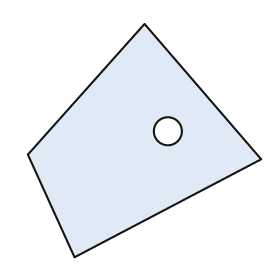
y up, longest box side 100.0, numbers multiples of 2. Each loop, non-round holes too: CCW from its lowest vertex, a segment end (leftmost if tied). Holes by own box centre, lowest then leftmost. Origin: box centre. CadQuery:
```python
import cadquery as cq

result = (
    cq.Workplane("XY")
    .moveTo(-30.0, -50.0)
    .lineTo(50.0, -8.0)
    .lineTo(0.0, 50.0)
    .lineTo(-50.0, -6.0)
    .close()
    .moveTo(10.0, 4.0)
    .circle(6.0)
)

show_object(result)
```